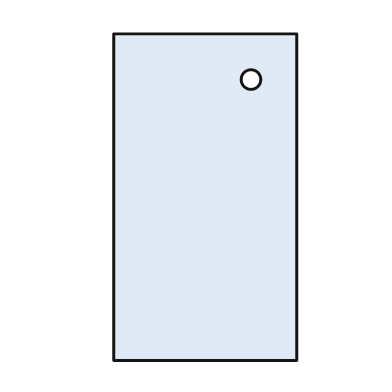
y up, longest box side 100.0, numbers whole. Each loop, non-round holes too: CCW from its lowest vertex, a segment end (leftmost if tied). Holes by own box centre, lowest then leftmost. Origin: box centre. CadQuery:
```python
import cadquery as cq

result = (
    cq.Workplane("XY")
    .moveTo(-28.0, -50.0)
    .lineTo(28.0, -50.0)
    .lineTo(28.0, 50.0)
    .lineTo(-28.0, 50.0)
    .close()
    .moveTo(14.0, 36.0)
    .circle(3.0)
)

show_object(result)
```